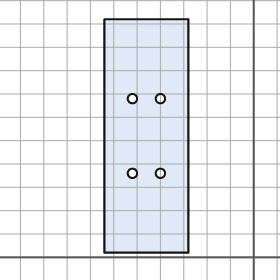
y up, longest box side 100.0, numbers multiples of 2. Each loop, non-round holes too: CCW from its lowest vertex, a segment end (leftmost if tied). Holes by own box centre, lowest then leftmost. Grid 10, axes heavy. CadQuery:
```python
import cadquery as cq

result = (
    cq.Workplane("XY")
    .moveTo(-64.0, 2.0)
    .lineTo(-28.0, 2.0)
    .lineTo(-28.0, 102.0)
    .lineTo(-64.0, 102.0)
    .close()
    .moveTo(-52.0, 36.0)
    .circle(2.0)
    .moveTo(-40.0, 36.0)
    .circle(2.0)
    .moveTo(-52.0, 68.0)
    .circle(2.0)
    .moveTo(-40.0, 68.0)
    .circle(2.0)
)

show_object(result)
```